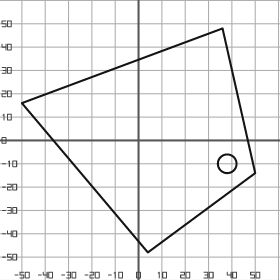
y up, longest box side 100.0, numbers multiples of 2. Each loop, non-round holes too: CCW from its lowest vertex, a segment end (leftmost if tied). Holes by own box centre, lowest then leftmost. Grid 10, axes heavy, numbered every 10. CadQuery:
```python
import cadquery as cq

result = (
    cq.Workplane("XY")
    .moveTo(4.0, -48.0)
    .lineTo(50.0, -14.0)
    .lineTo(36.0, 48.0)
    .lineTo(-50.0, 16.0)
    .close()
    .moveTo(38.0, -10.0)
    .circle(4.0)
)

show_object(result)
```